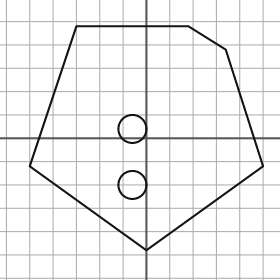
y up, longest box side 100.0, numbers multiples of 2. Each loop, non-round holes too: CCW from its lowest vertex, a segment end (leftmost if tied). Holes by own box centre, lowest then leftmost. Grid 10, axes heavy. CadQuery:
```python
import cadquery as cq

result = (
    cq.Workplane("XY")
    .moveTo(0.0, -48.0)
    .lineTo(50.0, -12.0)
    .lineTo(34.0, 38.0)
    .lineTo(18.0, 48.0)
    .lineTo(-30.0, 48.0)
    .lineTo(-50.0, -12.0)
    .close()
    .moveTo(-6.0, -20.0)
    .circle(6.0)
    .moveTo(-6.0, 4.0)
    .circle(6.0)
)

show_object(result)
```